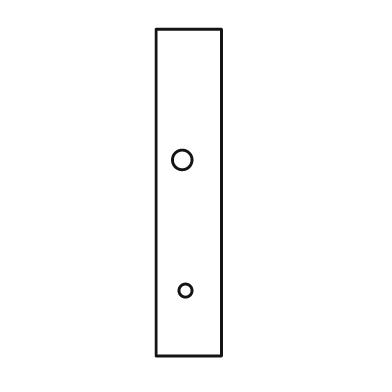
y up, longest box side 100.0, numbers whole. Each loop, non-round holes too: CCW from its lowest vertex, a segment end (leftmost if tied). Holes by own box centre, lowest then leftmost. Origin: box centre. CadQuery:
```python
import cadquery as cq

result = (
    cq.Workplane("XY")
    .moveTo(-10.0, -50.0)
    .lineTo(10.0, -50.0)
    .lineTo(10.0, 50.0)
    .lineTo(-10.0, 50.0)
    .close()
    .moveTo(-1.0, -30.0)
    .circle(2.0)
    .moveTo(-2.0, 10.0)
    .circle(3.0)
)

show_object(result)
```